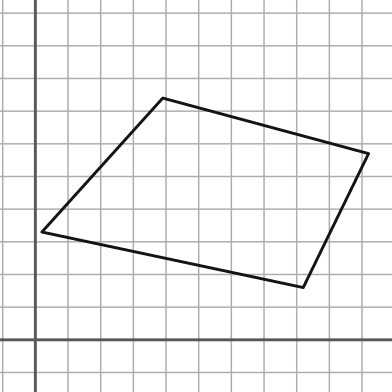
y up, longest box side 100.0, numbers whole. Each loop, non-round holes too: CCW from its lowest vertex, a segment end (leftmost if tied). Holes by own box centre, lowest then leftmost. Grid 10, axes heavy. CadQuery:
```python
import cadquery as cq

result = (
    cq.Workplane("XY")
    .moveTo(82.0, 16.0)
    .lineTo(102.0, 57.0)
    .lineTo(39.0, 74.0)
    .lineTo(2.0, 33.0)
    .close()
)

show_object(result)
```